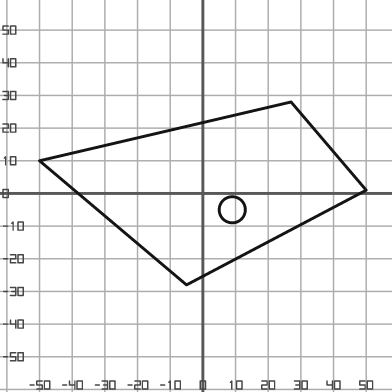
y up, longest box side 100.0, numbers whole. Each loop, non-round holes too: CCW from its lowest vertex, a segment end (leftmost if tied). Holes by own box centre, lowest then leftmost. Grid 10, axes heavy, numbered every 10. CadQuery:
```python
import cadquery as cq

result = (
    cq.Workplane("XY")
    .moveTo(-5.0, -28.0)
    .lineTo(50.0, 1.0)
    .lineTo(27.0, 28.0)
    .lineTo(-50.0, 10.0)
    .close()
    .moveTo(9.0, -5.0)
    .circle(4.0)
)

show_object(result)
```